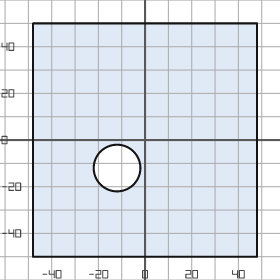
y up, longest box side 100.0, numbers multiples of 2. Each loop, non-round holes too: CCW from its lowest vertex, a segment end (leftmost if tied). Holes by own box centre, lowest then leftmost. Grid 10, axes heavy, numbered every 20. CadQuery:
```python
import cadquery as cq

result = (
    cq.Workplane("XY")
    .moveTo(-48.0, -50.0)
    .lineTo(48.0, -50.0)
    .lineTo(48.0, 50.0)
    .lineTo(-48.0, 50.0)
    .close()
    .moveTo(-12.0, -12.0)
    .circle(10.0)
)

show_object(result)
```